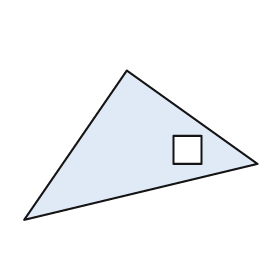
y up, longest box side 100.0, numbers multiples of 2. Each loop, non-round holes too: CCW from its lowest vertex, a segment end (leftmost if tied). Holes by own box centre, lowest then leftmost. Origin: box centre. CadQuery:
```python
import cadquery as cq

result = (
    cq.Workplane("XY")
    .moveTo(-50.0, -32.0)
    .lineTo(50.0, -8.0)
    .lineTo(-6.0, 32.0)
    .close()
    .moveTo(14.0, -8.0)
    .lineTo(26.0, -8.0)
    .lineTo(26.0, 4.0)
    .lineTo(14.0, 4.0)
    .close()
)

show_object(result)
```